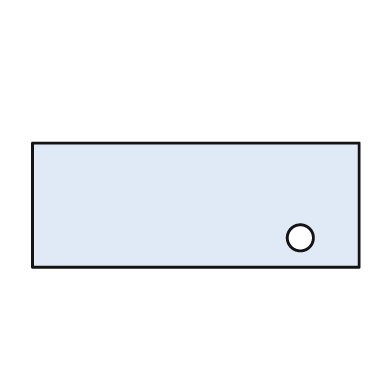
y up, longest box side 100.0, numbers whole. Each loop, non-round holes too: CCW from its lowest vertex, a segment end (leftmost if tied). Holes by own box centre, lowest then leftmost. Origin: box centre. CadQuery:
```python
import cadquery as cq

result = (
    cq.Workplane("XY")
    .moveTo(-50.0, -19.0)
    .lineTo(50.0, -19.0)
    .lineTo(50.0, 19.0)
    .lineTo(-50.0, 19.0)
    .close()
    .moveTo(32.0, -10.0)
    .circle(4.0)
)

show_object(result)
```